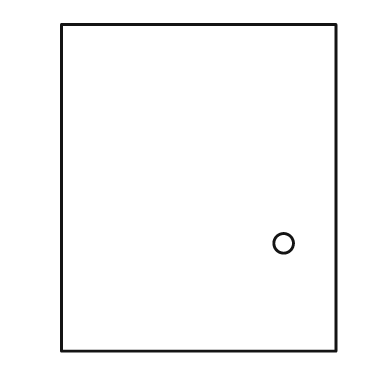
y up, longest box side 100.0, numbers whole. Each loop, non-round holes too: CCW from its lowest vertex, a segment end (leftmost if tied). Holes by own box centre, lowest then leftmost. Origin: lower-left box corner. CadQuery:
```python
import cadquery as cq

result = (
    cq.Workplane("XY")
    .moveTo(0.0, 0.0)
    .lineTo(84.0, 0.0)
    .lineTo(84.0, 100.0)
    .lineTo(0.0, 100.0)
    .close()
    .moveTo(68.0, 33.0)
    .circle(3.0)
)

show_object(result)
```